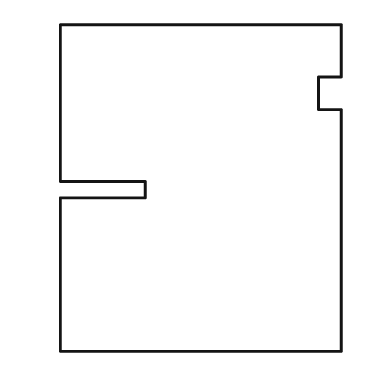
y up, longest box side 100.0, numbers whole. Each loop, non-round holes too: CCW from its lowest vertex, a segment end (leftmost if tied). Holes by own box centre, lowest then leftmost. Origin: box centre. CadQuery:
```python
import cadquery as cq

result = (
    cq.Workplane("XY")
    .moveTo(-43.0, -50.0)
    .lineTo(43.0, -50.0)
    .lineTo(43.0, 24.0)
    .lineTo(36.0, 24.0)
    .lineTo(36.0, 34.0)
    .lineTo(43.0, 34.0)
    .lineTo(43.0, 50.0)
    .lineTo(-43.0, 50.0)
    .lineTo(-43.0, 2.0)
    .lineTo(-17.0, 2.0)
    .lineTo(-17.0, -3.0)
    .lineTo(-43.0, -3.0)
    .close()
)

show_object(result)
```